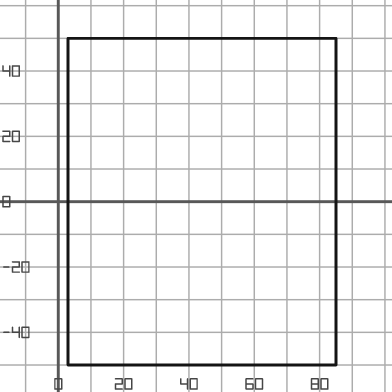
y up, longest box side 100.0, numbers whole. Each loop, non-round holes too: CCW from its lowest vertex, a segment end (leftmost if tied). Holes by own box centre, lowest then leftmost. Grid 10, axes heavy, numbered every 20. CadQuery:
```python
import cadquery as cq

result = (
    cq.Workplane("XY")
    .moveTo(3.0, -50.0)
    .lineTo(85.0, -50.0)
    .lineTo(85.0, 50.0)
    .lineTo(3.0, 50.0)
    .close()
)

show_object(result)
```